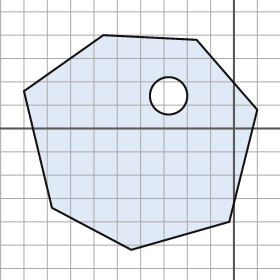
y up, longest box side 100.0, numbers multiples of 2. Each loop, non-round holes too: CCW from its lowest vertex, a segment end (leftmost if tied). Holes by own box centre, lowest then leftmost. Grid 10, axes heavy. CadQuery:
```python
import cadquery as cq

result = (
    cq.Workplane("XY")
    .moveTo(-44.0, -52.0)
    .lineTo(-2.0, -40.0)
    .lineTo(10.0, 8.0)
    .lineTo(-16.0, 38.0)
    .lineTo(-56.0, 40.0)
    .lineTo(-90.0, 16.0)
    .lineTo(-78.0, -34.0)
    .close()
    .moveTo(-28.0, 14.0)
    .circle(8.0)
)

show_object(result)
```